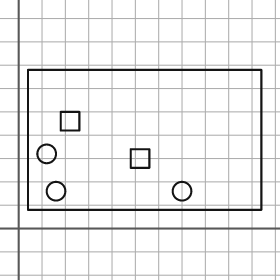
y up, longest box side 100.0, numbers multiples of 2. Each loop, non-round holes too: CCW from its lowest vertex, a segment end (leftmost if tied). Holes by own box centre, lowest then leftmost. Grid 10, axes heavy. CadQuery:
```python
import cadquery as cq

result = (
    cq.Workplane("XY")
    .moveTo(4.0, 8.0)
    .lineTo(104.0, 8.0)
    .lineTo(104.0, 68.0)
    .lineTo(4.0, 68.0)
    .close()
    .moveTo(16.0, 16.0)
    .circle(4.0)
    .moveTo(70.0, 16.0)
    .circle(4.0)
    .moveTo(48.0, 26.0)
    .lineTo(56.0, 26.0)
    .lineTo(56.0, 34.0)
    .lineTo(48.0, 34.0)
    .close()
    .moveTo(12.0, 32.0)
    .circle(4.0)
    .moveTo(18.0, 42.0)
    .lineTo(26.0, 42.0)
    .lineTo(26.0, 50.0)
    .lineTo(18.0, 50.0)
    .close()
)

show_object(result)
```